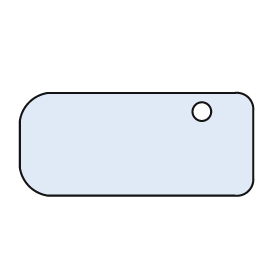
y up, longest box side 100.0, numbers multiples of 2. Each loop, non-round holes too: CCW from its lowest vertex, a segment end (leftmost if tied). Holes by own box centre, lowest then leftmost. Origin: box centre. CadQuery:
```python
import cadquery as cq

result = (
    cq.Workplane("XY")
    .moveTo(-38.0, -22.0)
    .lineTo(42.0, -22.0)
    .threePointArc((48.0, -20.0), (50.0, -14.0))
    .lineTo(50.0, 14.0)
    .threePointArc((48.0, 20.0), (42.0, 22.0))
    .lineTo(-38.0, 22.0)
    .threePointArc((-46.0, 18.0), (-50.0, 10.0))
    .lineTo(-50.0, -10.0)
    .threePointArc((-46.0, -18.0), (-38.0, -22.0))
    .close()
    .moveTo(28.0, 14.0)
    .circle(4.0)
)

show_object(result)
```